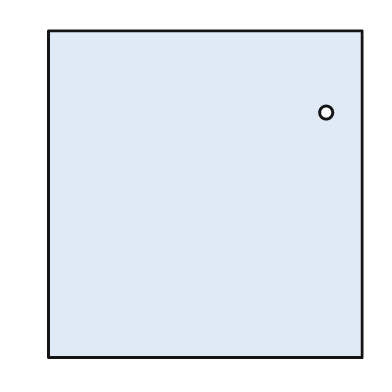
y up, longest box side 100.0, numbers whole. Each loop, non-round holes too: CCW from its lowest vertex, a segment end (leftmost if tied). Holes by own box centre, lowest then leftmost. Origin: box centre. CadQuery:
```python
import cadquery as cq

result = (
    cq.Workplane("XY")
    .moveTo(-48.0, -50.0)
    .lineTo(48.0, -50.0)
    .lineTo(48.0, 50.0)
    .lineTo(-48.0, 50.0)
    .close()
    .moveTo(37.0, 25.0)
    .circle(2.0)
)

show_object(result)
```